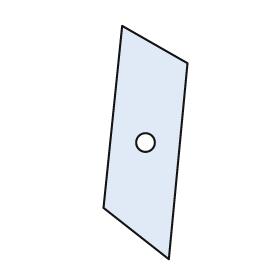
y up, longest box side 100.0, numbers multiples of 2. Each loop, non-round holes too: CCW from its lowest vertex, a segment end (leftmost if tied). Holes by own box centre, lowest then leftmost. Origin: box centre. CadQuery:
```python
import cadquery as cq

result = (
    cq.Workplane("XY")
    .moveTo(10.0, -50.0)
    .lineTo(18.0, 34.0)
    .lineTo(-10.0, 50.0)
    .lineTo(-18.0, -28.0)
    .close()
    .moveTo(0.0, 0.0)
    .circle(4.0)
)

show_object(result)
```